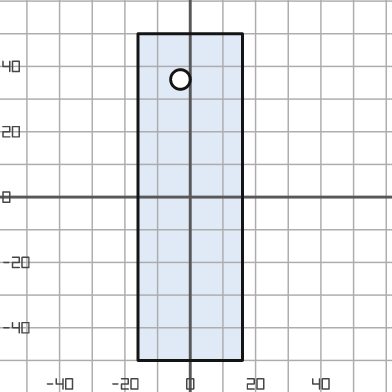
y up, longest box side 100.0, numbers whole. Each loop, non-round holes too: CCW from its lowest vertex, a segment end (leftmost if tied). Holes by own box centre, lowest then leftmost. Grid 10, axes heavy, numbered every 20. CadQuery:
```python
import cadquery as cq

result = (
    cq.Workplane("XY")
    .moveTo(-16.0, -50.0)
    .lineTo(16.0, -50.0)
    .lineTo(16.0, 50.0)
    .lineTo(-16.0, 50.0)
    .close()
    .moveTo(-3.0, 36.0)
    .circle(3.0)
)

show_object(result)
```